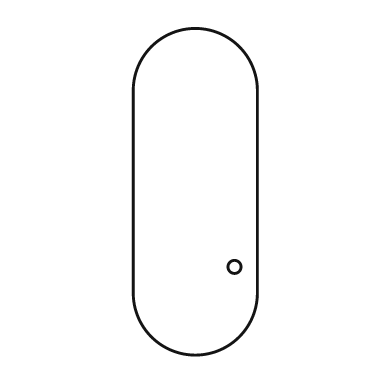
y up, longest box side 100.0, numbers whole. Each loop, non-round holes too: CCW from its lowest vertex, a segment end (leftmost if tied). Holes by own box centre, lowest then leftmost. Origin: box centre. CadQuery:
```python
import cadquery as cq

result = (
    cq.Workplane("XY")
    .moveTo(-19.0, -31.0)
    .threePointArc((0.0, -50.0), (19.0, -31.0))
    .lineTo(19.0, 31.0)
    .threePointArc((0.0, 50.0), (-19.0, 31.0))
    .close()
    .moveTo(12.0, -23.0)
    .circle(2.0)
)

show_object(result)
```